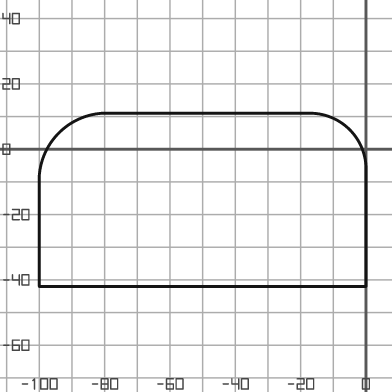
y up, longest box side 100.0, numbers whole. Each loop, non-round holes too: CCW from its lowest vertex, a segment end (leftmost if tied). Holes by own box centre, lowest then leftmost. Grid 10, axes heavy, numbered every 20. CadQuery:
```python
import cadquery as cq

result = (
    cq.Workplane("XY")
    .moveTo(-100.0, -42.0)
    .lineTo(0.0, -42.0)
    .lineTo(0.0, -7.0)
    .threePointArc((-5.0, 6.0), (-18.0, 11.0))
    .lineTo(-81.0, 11.0)
    .threePointArc((-94.0, 5.0), (-100.0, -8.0))
    .close()
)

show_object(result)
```